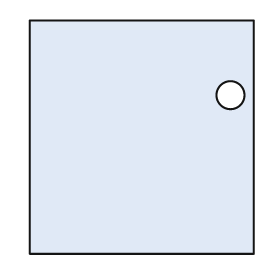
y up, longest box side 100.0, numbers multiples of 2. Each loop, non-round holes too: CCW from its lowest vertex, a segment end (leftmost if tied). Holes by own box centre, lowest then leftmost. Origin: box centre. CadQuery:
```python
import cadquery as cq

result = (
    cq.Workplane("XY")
    .moveTo(-48.0, -50.0)
    .lineTo(48.0, -50.0)
    .lineTo(48.0, 50.0)
    .lineTo(-48.0, 50.0)
    .close()
    .moveTo(38.0, 18.0)
    .circle(6.0)
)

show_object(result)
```